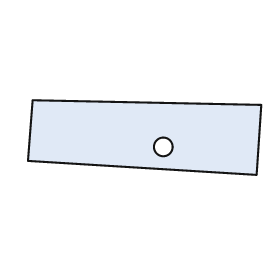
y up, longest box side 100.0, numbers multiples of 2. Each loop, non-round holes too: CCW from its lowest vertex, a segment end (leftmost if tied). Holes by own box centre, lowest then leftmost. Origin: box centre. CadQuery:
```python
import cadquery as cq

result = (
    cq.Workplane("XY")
    .moveTo(48.0, -16.0)
    .lineTo(50.0, 14.0)
    .lineTo(-48.0, 16.0)
    .lineTo(-50.0, -10.0)
    .close()
    .moveTo(8.0, -4.0)
    .circle(4.0)
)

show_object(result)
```